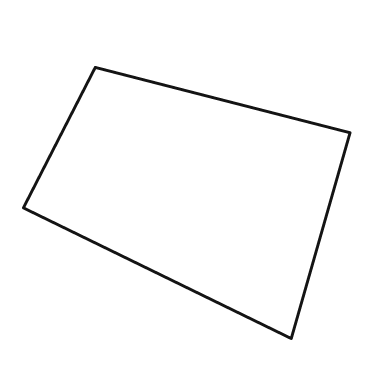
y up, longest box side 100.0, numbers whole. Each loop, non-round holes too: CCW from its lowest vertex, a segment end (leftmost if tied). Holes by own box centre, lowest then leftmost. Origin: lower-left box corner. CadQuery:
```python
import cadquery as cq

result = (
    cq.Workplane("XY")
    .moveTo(82.0, 0.0)
    .lineTo(100.0, 63.0)
    .lineTo(22.0, 83.0)
    .lineTo(0.0, 40.0)
    .close()
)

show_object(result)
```